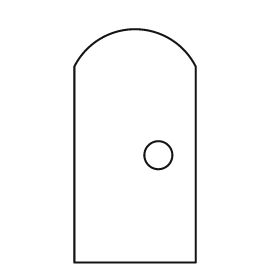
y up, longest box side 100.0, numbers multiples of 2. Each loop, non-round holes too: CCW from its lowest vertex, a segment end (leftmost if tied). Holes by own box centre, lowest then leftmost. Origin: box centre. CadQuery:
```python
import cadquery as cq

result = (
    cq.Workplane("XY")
    .moveTo(-26.0, -50.0)
    .lineTo(26.0, -50.0)
    .lineTo(26.0, 34.0)
    .threePointArc((0.0, 50.0), (-26.0, 34.0))
    .close()
    .moveTo(10.0, -4.0)
    .circle(6.0)
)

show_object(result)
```